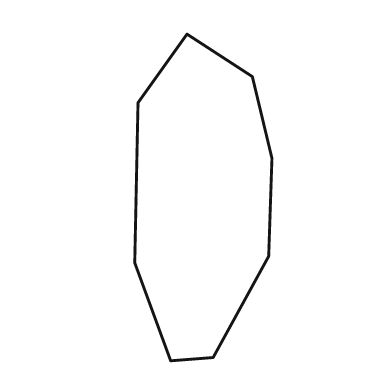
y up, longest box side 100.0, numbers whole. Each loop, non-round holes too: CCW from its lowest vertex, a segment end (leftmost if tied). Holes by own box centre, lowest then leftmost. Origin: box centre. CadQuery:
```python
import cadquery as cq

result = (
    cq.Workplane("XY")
    .moveTo(-10.0, -50.0)
    .lineTo(3.0, -49.0)
    .lineTo(20.0, -18.0)
    .lineTo(21.0, 12.0)
    .lineTo(15.0, 37.0)
    .lineTo(-5.0, 50.0)
    .lineTo(-20.0, 29.0)
    .lineTo(-21.0, -20.0)
    .close()
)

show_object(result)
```